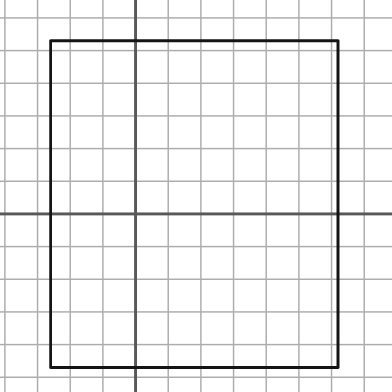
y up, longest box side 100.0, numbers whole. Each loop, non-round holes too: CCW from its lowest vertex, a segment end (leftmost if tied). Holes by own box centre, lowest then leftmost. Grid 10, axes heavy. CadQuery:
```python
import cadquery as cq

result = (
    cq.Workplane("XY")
    .moveTo(-26.0, -47.0)
    .lineTo(62.0, -47.0)
    .lineTo(62.0, 53.0)
    .lineTo(-26.0, 53.0)
    .close()
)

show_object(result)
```